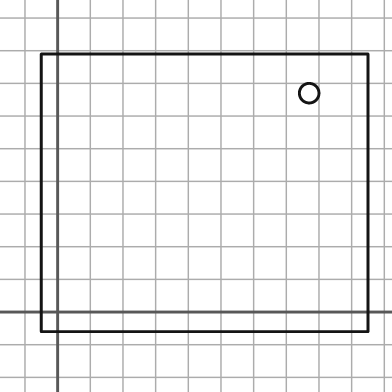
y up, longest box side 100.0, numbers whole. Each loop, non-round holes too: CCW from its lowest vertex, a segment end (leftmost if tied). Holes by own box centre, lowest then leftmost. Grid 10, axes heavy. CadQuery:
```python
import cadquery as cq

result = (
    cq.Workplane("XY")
    .moveTo(-5.0, -6.0)
    .lineTo(95.0, -6.0)
    .lineTo(95.0, 79.0)
    .lineTo(-5.0, 79.0)
    .close()
    .moveTo(77.0, 67.0)
    .circle(3.0)
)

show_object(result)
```